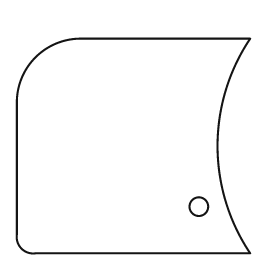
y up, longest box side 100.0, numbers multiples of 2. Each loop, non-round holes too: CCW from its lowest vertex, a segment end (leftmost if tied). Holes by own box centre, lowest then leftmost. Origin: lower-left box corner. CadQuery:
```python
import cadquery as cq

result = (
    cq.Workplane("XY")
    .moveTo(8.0, 0.0)
    .lineTo(100.0, 0.0)
    .threePointArc((86.0, 46.0), (100.0, 92.0))
    .lineTo(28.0, 92.0)
    .threePointArc((8.0, 84.0), (0.0, 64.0))
    .lineTo(0.0, 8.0)
    .threePointArc((2.0, 2.0), (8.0, 0.0))
    .close()
    .moveTo(78.0, 20.0)
    .circle(4.0)
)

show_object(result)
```